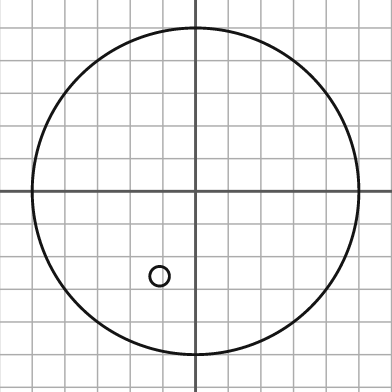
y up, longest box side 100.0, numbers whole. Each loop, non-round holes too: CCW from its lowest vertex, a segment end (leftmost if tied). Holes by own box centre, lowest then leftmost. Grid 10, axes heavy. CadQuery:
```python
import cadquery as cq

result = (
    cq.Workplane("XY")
    .moveTo(0.0, 0.0)
    .circle(50.0)
    .moveTo(-11.0, -26.0)
    .circle(3.0)
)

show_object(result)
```